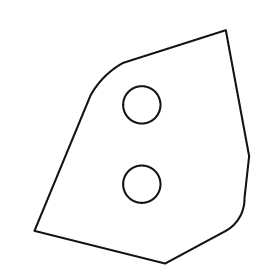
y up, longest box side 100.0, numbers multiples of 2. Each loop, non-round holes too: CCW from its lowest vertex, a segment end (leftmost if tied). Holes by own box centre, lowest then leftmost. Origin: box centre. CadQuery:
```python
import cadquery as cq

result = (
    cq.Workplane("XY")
    .moveTo(10.0, -50.0)
    .lineTo(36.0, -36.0)
    .threePointArc((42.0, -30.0), (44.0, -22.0))
    .lineTo(46.0, -4.0)
    .lineTo(36.0, 50.0)
    .lineTo(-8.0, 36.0)
    .threePointArc((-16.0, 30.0), (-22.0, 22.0))
    .lineTo(-46.0, -36.0)
    .close()
    .moveTo(0.0, -16.0)
    .circle(8.0)
    .moveTo(0.0, 18.0)
    .circle(8.0)
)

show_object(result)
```